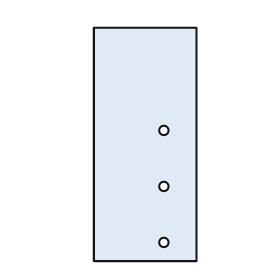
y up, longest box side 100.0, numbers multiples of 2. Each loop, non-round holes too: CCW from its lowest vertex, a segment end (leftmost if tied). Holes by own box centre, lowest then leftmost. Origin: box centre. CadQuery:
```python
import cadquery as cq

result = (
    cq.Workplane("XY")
    .moveTo(-22.0, -50.0)
    .lineTo(22.0, -50.0)
    .lineTo(22.0, 50.0)
    .lineTo(-22.0, 50.0)
    .close()
    .moveTo(8.0, -42.0)
    .circle(2.0)
    .moveTo(8.0, -18.0)
    .circle(2.0)
    .moveTo(8.0, 6.0)
    .circle(2.0)
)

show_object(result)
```